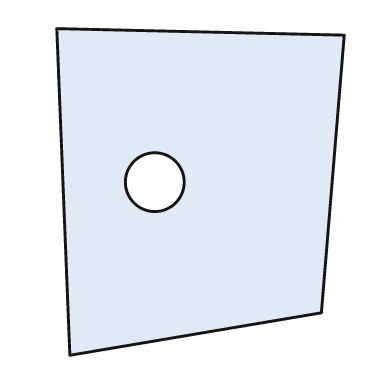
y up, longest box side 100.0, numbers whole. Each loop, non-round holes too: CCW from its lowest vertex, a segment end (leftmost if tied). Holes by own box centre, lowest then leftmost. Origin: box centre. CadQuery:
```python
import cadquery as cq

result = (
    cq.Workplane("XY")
    .moveTo(-40.0, -50.0)
    .lineTo(37.0, -37.0)
    .lineTo(44.0, 48.0)
    .lineTo(-44.0, 50.0)
    .close()
    .moveTo(-14.0, 3.0)
    .circle(9.0)
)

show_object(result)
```